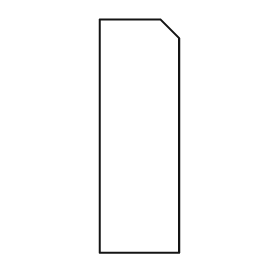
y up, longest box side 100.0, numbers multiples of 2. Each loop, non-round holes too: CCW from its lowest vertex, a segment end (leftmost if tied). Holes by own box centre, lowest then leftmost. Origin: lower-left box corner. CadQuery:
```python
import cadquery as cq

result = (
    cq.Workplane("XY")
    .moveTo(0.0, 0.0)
    .lineTo(34.0, 0.0)
    .lineTo(34.0, 92.0)
    .lineTo(26.0, 100.0)
    .lineTo(0.0, 100.0)
    .close()
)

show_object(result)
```